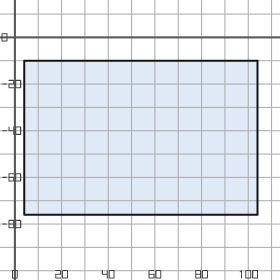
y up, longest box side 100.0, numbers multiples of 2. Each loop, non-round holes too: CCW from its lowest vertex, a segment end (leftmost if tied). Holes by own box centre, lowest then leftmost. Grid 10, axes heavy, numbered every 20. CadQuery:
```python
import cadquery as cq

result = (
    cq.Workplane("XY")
    .moveTo(4.0, -76.0)
    .lineTo(104.0, -76.0)
    .lineTo(104.0, -10.0)
    .lineTo(4.0, -10.0)
    .close()
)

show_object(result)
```